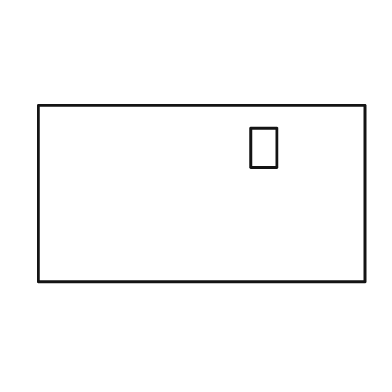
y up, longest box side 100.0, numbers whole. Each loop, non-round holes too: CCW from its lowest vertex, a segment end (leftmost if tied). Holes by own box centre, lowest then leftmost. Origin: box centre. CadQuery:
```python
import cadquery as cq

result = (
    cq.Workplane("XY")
    .moveTo(-50.0, -27.0)
    .lineTo(50.0, -27.0)
    .lineTo(50.0, 27.0)
    .lineTo(-50.0, 27.0)
    .close()
    .moveTo(15.0, 8.0)
    .lineTo(23.0, 8.0)
    .lineTo(23.0, 20.0)
    .lineTo(15.0, 20.0)
    .close()
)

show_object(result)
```